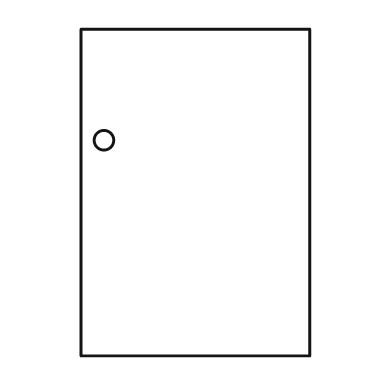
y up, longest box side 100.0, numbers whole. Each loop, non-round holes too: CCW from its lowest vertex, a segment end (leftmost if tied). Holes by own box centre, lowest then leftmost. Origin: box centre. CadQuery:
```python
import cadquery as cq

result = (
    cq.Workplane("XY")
    .moveTo(-35.0, -50.0)
    .lineTo(35.0, -50.0)
    .lineTo(35.0, 50.0)
    .lineTo(-35.0, 50.0)
    .close()
    .moveTo(-28.0, 16.0)
    .circle(3.0)
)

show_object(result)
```